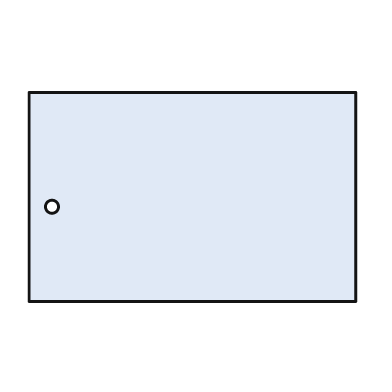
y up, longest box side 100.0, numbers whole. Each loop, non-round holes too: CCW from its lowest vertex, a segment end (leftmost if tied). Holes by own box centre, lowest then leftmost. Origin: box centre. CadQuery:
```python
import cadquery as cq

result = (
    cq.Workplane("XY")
    .moveTo(-50.0, -32.0)
    .lineTo(50.0, -32.0)
    .lineTo(50.0, 32.0)
    .lineTo(-50.0, 32.0)
    .close()
    .moveTo(-43.0, -3.0)
    .circle(2.0)
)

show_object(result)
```